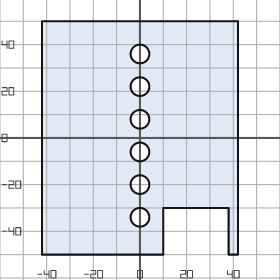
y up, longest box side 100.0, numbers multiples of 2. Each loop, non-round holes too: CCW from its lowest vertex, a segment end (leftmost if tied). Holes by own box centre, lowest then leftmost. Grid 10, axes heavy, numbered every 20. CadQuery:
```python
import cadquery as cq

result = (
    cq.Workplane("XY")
    .moveTo(-42.0, -50.0)
    .lineTo(10.0, -50.0)
    .lineTo(10.0, -30.0)
    .lineTo(38.0, -30.0)
    .lineTo(38.0, -50.0)
    .lineTo(42.0, -50.0)
    .lineTo(42.0, 50.0)
    .lineTo(-42.0, 50.0)
    .close()
    .moveTo(0.0, -34.0)
    .circle(4.0)
    .moveTo(0.0, -20.0)
    .circle(4.0)
    .moveTo(0.0, -6.0)
    .circle(4.0)
    .moveTo(0.0, 8.0)
    .circle(4.0)
    .moveTo(0.0, 22.0)
    .circle(4.0)
    .moveTo(0.0, 36.0)
    .circle(4.0)
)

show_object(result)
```